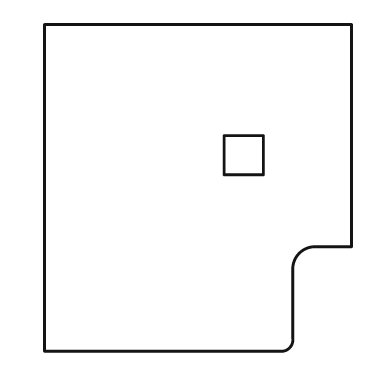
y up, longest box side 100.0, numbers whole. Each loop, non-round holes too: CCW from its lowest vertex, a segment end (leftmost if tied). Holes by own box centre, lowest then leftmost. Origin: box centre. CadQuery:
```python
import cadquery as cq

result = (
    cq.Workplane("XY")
    .moveTo(-47.0, -50.0)
    .lineTo(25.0, -50.0)
    .threePointArc((28.0, -49.0), (29.0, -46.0))
    .lineTo(29.0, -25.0)
    .threePointArc((31.0, -20.0), (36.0, -18.0))
    .lineTo(47.0, -18.0)
    .lineTo(47.0, 50.0)
    .lineTo(-47.0, 50.0)
    .close()
    .moveTo(8.0, 4.0)
    .lineTo(20.0, 4.0)
    .lineTo(20.0, 16.0)
    .lineTo(8.0, 16.0)
    .close()
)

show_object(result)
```